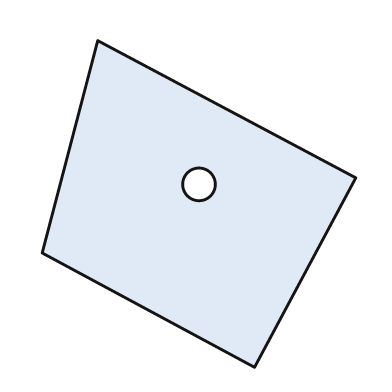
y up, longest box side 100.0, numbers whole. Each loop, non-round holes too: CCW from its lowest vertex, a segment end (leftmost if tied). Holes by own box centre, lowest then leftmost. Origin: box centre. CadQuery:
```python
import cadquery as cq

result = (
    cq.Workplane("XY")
    .moveTo(17.0, -50.0)
    .lineTo(48.0, 8.0)
    .lineTo(-31.0, 50.0)
    .lineTo(-48.0, -15.0)
    .close()
    .moveTo(0.0, 6.0)
    .circle(5.0)
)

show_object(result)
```